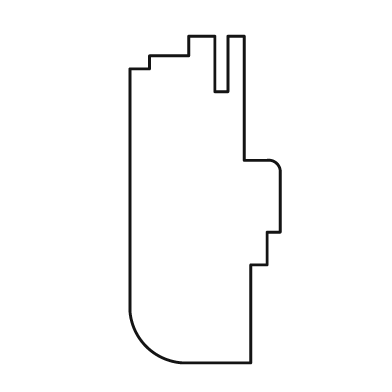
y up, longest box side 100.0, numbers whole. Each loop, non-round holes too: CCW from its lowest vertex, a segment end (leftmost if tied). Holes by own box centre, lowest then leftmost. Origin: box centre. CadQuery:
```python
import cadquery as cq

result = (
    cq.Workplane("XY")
    .moveTo(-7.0, -50.0)
    .lineTo(14.0, -50.0)
    .lineTo(14.0, -20.0)
    .lineTo(19.0, -20.0)
    .lineTo(19.0, -10.0)
    .lineTo(23.0, -10.0)
    .lineTo(23.0, 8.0)
    .threePointArc((22.0, 11.0), (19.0, 12.0))
    .lineTo(12.0, 12.0)
    .lineTo(12.0, 50.0)
    .lineTo(7.0, 50.0)
    .lineTo(7.0, 33.0)
    .lineTo(3.0, 33.0)
    .lineTo(3.0, 50.0)
    .lineTo(-5.0, 50.0)
    .lineTo(-5.0, 44.0)
    .lineTo(-17.0, 44.0)
    .lineTo(-17.0, 40.0)
    .lineTo(-23.0, 40.0)
    .lineTo(-23.0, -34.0)
    .threePointArc((-18.0, -45.0), (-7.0, -50.0))
    .close()
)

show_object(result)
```